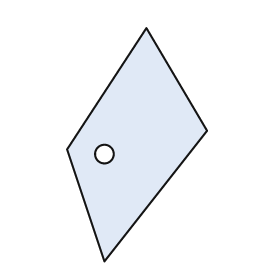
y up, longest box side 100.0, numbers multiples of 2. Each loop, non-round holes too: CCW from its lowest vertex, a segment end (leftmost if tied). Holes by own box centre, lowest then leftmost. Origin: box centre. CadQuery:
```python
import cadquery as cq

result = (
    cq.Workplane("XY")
    .moveTo(-14.0, -50.0)
    .lineTo(30.0, 6.0)
    .lineTo(4.0, 50.0)
    .lineTo(-30.0, -2.0)
    .close()
    .moveTo(-14.0, -4.0)
    .circle(4.0)
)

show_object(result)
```